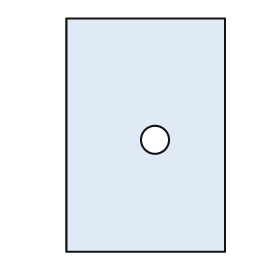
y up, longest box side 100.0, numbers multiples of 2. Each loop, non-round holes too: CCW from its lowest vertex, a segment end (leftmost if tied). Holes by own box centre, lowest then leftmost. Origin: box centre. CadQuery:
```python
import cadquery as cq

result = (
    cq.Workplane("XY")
    .moveTo(-34.0, -50.0)
    .lineTo(34.0, -50.0)
    .lineTo(34.0, 50.0)
    .lineTo(-34.0, 50.0)
    .close()
    .moveTo(4.0, -2.0)
    .circle(6.0)
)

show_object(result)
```